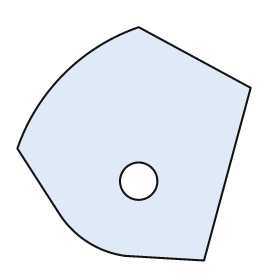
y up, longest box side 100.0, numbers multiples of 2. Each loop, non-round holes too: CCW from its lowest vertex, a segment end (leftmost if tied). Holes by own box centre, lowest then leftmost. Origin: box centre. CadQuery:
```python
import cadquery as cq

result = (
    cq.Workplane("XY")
    .moveTo(30.0, -50.0)
    .lineTo(50.0, 24.0)
    .lineTo(2.0, 50.0)
    .threePointArc((-30.0, 30.0), (-50.0, -2.0))
    .lineTo(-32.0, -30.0)
    .threePointArc((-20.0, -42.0), (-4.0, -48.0))
    .close()
    .moveTo(2.0, -16.0)
    .circle(8.0)
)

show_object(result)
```